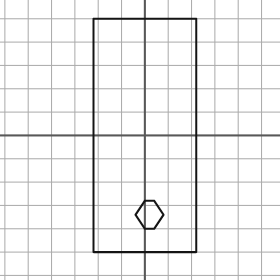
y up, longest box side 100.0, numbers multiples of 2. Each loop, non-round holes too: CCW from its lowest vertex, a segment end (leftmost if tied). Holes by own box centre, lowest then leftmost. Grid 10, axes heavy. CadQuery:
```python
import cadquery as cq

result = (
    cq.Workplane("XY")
    .moveTo(-22.0, -50.0)
    .lineTo(22.0, -50.0)
    .lineTo(22.0, 50.0)
    .lineTo(-22.0, 50.0)
    .close()
    .moveTo(0.0, -40.0)
    .lineTo(4.0, -40.0)
    .lineTo(8.0, -34.0)
    .lineTo(4.0, -28.0)
    .lineTo(0.0, -28.0)
    .lineTo(-4.0, -34.0)
    .close()
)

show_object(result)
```